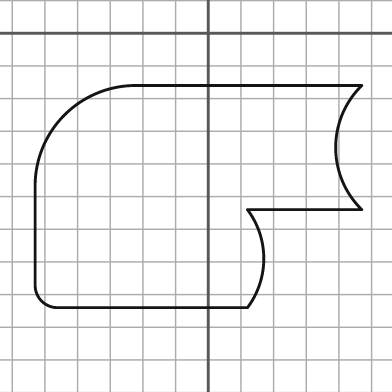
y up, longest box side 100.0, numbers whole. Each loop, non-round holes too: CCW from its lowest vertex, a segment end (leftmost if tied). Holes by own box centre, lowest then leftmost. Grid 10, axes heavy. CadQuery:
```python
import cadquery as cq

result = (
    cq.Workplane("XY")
    .moveTo(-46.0, -84.0)
    .lineTo(12.0, -84.0)
    .threePointArc((17.0, -69.0), (12.0, -54.0))
    .lineTo(47.0, -54.0)
    .threePointArc((39.0, -35.0), (47.0, -16.0))
    .lineTo(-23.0, -16.0)
    .threePointArc((-44.0, -25.0), (-53.0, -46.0))
    .lineTo(-53.0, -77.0)
    .threePointArc((-51.0, -82.0), (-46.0, -84.0))
    .close()
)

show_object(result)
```